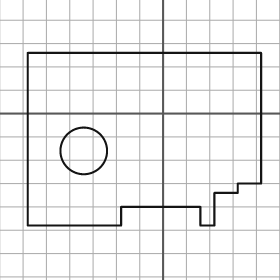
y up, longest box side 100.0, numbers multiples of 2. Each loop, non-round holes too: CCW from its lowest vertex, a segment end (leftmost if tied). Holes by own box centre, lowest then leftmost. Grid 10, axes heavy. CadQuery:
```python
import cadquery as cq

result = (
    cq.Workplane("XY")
    .moveTo(-58.0, -48.0)
    .lineTo(-18.0, -48.0)
    .lineTo(-18.0, -40.0)
    .lineTo(16.0, -40.0)
    .lineTo(16.0, -48.0)
    .lineTo(22.0, -48.0)
    .lineTo(22.0, -34.0)
    .lineTo(32.0, -34.0)
    .lineTo(32.0, -30.0)
    .lineTo(42.0, -30.0)
    .lineTo(42.0, 26.0)
    .lineTo(-58.0, 26.0)
    .close()
    .moveTo(-34.0, -16.0)
    .circle(10.0)
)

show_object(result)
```